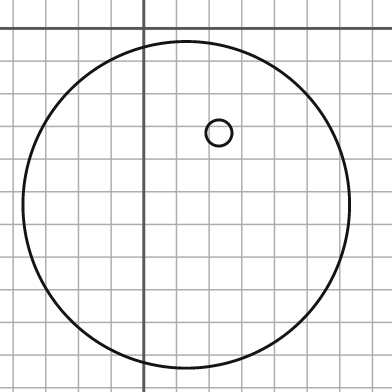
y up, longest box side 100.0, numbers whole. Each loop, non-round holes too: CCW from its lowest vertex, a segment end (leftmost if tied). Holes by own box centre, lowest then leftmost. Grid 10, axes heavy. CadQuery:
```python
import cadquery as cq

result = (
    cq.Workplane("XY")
    .moveTo(13.0, -54.0)
    .circle(50.0)
    .moveTo(23.0, -32.0)
    .circle(4.0)
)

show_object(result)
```